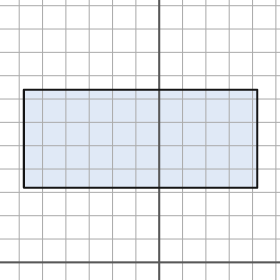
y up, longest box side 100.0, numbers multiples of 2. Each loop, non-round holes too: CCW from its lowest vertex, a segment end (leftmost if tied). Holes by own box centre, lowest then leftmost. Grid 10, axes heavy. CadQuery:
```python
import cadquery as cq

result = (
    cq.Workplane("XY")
    .moveTo(-58.0, 32.0)
    .lineTo(42.0, 32.0)
    .lineTo(42.0, 74.0)
    .lineTo(-58.0, 74.0)
    .close()
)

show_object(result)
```